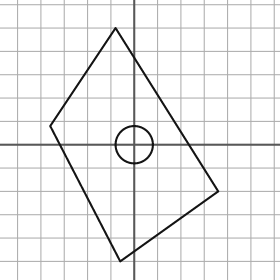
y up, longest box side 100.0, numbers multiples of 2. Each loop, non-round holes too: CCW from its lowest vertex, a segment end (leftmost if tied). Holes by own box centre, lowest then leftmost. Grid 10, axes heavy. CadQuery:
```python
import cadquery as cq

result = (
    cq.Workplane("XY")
    .moveTo(-6.0, -50.0)
    .lineTo(36.0, -20.0)
    .lineTo(-8.0, 50.0)
    .lineTo(-36.0, 8.0)
    .close()
    .moveTo(0.0, 0.0)
    .circle(8.0)
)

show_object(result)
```